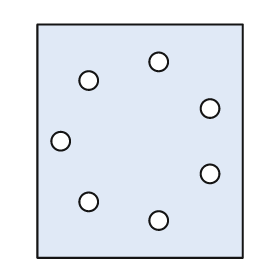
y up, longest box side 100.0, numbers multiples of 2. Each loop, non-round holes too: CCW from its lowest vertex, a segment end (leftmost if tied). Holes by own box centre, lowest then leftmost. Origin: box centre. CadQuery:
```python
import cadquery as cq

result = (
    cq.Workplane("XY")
    .moveTo(-44.0, -50.0)
    .lineTo(44.0, -50.0)
    .lineTo(44.0, 50.0)
    .lineTo(-44.0, 50.0)
    .close()
    .moveTo(8.0, -34.0)
    .circle(4.0)
    .moveTo(-22.0, -26.0)
    .circle(4.0)
    .moveTo(30.0, -14.0)
    .circle(4.0)
    .moveTo(-34.0, 0.0)
    .circle(4.0)
    .moveTo(30.0, 14.0)
    .circle(4.0)
    .moveTo(-22.0, 26.0)
    .circle(4.0)
    .moveTo(8.0, 34.0)
    .circle(4.0)
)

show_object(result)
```